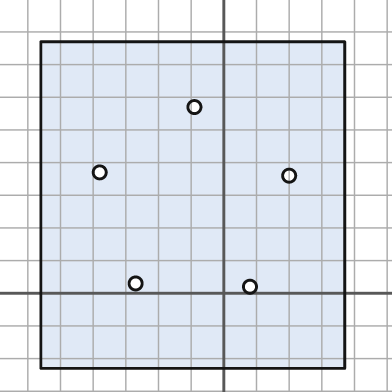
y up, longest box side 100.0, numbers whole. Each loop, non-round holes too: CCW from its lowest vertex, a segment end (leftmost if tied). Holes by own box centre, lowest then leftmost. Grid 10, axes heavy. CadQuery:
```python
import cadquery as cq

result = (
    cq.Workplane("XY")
    .moveTo(-56.0, -23.0)
    .lineTo(37.0, -23.0)
    .lineTo(37.0, 77.0)
    .lineTo(-56.0, 77.0)
    .close()
    .moveTo(8.0, 2.0)
    .circle(2.0)
    .moveTo(-27.0, 3.0)
    .circle(2.0)
    .moveTo(20.0, 36.0)
    .circle(2.0)
    .moveTo(-38.0, 37.0)
    .circle(2.0)
    .moveTo(-9.0, 57.0)
    .circle(2.0)
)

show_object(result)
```